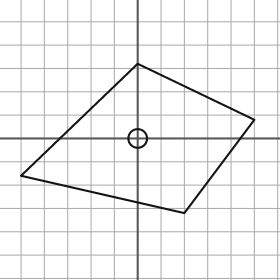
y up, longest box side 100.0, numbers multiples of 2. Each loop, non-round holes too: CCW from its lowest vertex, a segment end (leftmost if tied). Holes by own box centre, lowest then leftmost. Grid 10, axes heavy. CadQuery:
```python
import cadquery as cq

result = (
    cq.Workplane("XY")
    .moveTo(20.0, -32.0)
    .lineTo(50.0, 8.0)
    .lineTo(0.0, 32.0)
    .lineTo(-50.0, -16.0)
    .close()
    .moveTo(0.0, 0.0)
    .circle(4.0)
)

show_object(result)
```